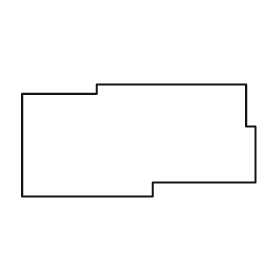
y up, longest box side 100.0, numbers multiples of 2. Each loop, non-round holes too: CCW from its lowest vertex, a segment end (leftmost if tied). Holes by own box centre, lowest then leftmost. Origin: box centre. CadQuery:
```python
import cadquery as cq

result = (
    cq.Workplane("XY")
    .moveTo(-50.0, -24.0)
    .lineTo(6.0, -24.0)
    .lineTo(6.0, -18.0)
    .lineTo(50.0, -18.0)
    .lineTo(50.0, 6.0)
    .lineTo(46.0, 6.0)
    .lineTo(46.0, 24.0)
    .lineTo(-18.0, 24.0)
    .lineTo(-18.0, 20.0)
    .lineTo(-50.0, 20.0)
    .close()
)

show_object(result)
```